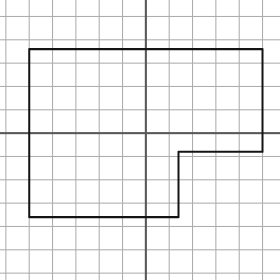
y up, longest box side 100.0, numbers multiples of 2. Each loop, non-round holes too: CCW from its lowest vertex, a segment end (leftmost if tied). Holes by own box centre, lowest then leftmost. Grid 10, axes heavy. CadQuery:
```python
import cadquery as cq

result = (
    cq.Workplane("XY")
    .moveTo(-50.0, -36.0)
    .lineTo(14.0, -36.0)
    .lineTo(14.0, -8.0)
    .lineTo(50.0, -8.0)
    .lineTo(50.0, 36.0)
    .lineTo(-50.0, 36.0)
    .close()
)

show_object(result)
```